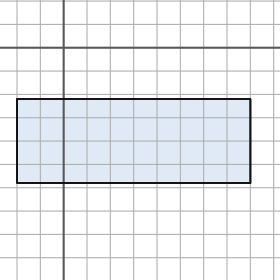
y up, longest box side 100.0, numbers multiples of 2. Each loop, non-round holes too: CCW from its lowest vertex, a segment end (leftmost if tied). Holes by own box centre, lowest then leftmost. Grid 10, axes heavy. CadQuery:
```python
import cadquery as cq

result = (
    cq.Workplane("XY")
    .moveTo(-20.0, -58.0)
    .lineTo(80.0, -58.0)
    .lineTo(80.0, -22.0)
    .lineTo(-20.0, -22.0)
    .close()
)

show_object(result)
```